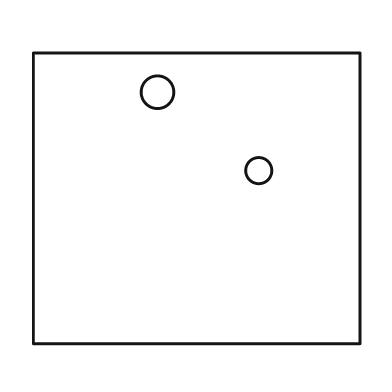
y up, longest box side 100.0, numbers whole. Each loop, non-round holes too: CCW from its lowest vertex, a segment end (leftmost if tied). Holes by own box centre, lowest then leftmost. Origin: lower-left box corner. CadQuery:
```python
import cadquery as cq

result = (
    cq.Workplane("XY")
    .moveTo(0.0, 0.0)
    .lineTo(100.0, 0.0)
    .lineTo(100.0, 89.0)
    .lineTo(0.0, 89.0)
    .close()
    .moveTo(69.0, 53.0)
    .circle(4.0)
    .moveTo(38.0, 77.0)
    .circle(5.0)
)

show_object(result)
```